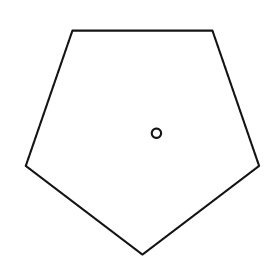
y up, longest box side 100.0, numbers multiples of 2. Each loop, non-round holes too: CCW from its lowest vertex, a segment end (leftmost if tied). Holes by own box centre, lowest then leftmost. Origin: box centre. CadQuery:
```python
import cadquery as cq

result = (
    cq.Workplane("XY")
    .moveTo(0.0, -48.0)
    .lineTo(50.0, -10.0)
    .lineTo(30.0, 48.0)
    .lineTo(-30.0, 48.0)
    .lineTo(-50.0, -10.0)
    .close()
    .moveTo(6.0, 4.0)
    .circle(2.0)
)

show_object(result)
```